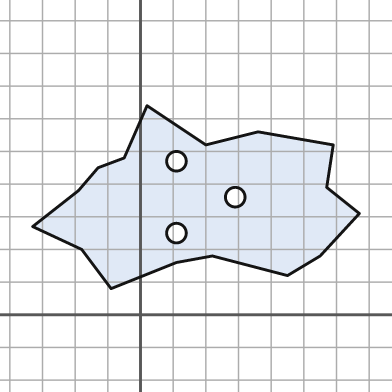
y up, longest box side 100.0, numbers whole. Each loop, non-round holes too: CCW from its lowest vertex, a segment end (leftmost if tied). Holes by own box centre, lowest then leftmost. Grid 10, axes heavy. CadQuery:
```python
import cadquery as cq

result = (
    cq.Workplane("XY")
    .moveTo(-9.0, 8.0)
    .lineTo(11.0, 16.0)
    .lineTo(22.0, 18.0)
    .lineTo(45.0, 12.0)
    .lineTo(55.0, 18.0)
    .lineTo(67.0, 31.0)
    .lineTo(57.0, 39.0)
    .lineTo(59.0, 52.0)
    .lineTo(36.0, 56.0)
    .lineTo(20.0, 52.0)
    .lineTo(2.0, 64.0)
    .lineTo(-5.0, 48.0)
    .lineTo(-13.0, 45.0)
    .lineTo(-19.0, 38.0)
    .lineTo(-33.0, 27.0)
    .lineTo(-18.0, 20.0)
    .close()
    .moveTo(11.0, 25.0)
    .circle(3.0)
    .moveTo(29.0, 36.0)
    .circle(3.0)
    .moveTo(11.0, 47.0)
    .circle(3.0)
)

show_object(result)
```